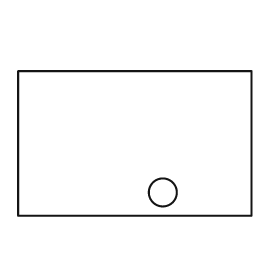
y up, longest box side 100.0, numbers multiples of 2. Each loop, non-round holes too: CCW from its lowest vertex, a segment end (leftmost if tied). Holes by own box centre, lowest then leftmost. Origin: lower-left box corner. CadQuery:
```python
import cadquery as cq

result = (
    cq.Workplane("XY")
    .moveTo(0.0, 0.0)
    .lineTo(100.0, 0.0)
    .lineTo(100.0, 62.0)
    .lineTo(0.0, 62.0)
    .close()
    .moveTo(62.0, 10.0)
    .circle(6.0)
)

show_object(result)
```